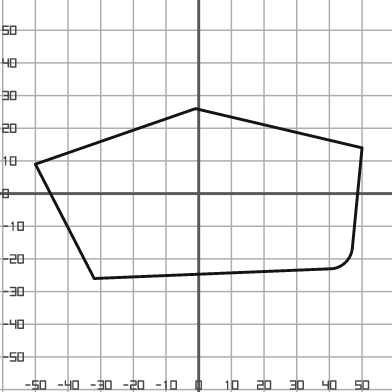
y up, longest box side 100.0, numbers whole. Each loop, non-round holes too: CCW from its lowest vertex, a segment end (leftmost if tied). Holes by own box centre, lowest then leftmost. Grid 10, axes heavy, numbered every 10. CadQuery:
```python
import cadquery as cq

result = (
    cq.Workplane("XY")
    .moveTo(-32.0, -26.0)
    .lineTo(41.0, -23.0)
    .threePointArc((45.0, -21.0), (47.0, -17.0))
    .lineTo(50.0, 14.0)
    .lineTo(-1.0, 26.0)
    .lineTo(-50.0, 9.0)
    .close()
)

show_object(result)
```